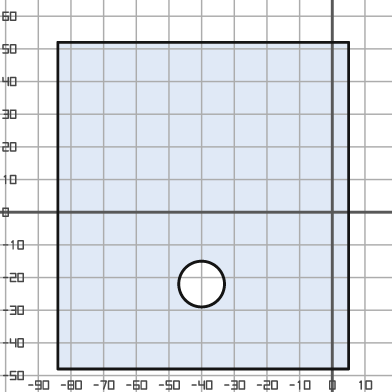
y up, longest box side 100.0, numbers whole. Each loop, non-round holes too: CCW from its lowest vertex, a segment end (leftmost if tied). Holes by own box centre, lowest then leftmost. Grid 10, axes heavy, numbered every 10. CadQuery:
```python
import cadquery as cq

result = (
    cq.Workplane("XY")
    .moveTo(-84.0, -48.0)
    .lineTo(5.0, -48.0)
    .lineTo(5.0, 52.0)
    .lineTo(-84.0, 52.0)
    .close()
    .moveTo(-40.0, -22.0)
    .circle(7.0)
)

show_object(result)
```